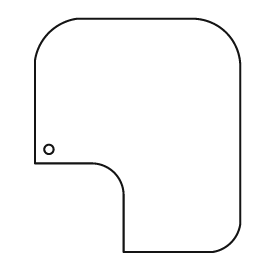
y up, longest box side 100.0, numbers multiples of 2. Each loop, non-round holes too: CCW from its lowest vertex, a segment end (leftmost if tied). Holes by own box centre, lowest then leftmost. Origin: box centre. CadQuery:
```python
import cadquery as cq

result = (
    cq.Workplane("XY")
    .moveTo(-6.0, -50.0)
    .lineTo(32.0, -50.0)
    .threePointArc((40.0, -46.0), (44.0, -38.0))
    .lineTo(44.0, 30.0)
    .threePointArc((38.0, 44.0), (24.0, 50.0))
    .lineTo(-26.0, 50.0)
    .threePointArc((-38.0, 44.0), (-44.0, 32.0))
    .lineTo(-44.0, -12.0)
    .lineTo(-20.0, -12.0)
    .threePointArc((-10.0, -16.0), (-6.0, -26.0))
    .close()
    .moveTo(-38.0, -6.0)
    .circle(2.0)
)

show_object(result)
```